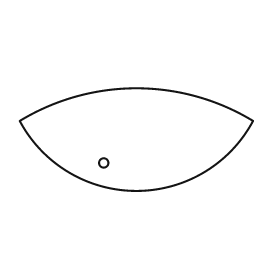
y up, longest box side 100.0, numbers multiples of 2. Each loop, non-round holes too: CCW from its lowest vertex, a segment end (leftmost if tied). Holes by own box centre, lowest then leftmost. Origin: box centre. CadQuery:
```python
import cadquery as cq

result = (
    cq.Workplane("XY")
    .moveTo(-50.0, 8.0)
    .threePointArc((0.0, -22.0), (50.0, 8.0))
    .threePointArc((0.0, 22.0), (-50.0, 8.0))
    .close()
    .moveTo(-14.0, -10.0)
    .circle(2.0)
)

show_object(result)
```